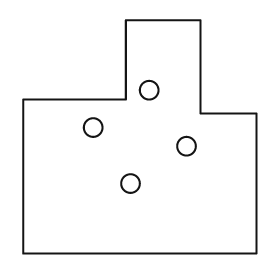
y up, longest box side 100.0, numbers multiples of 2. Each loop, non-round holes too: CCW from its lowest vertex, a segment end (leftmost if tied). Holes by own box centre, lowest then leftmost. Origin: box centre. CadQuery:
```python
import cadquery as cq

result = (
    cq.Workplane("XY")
    .moveTo(-50.0, -50.0)
    .lineTo(50.0, -50.0)
    .lineTo(50.0, 10.0)
    .lineTo(26.0, 10.0)
    .lineTo(26.0, 50.0)
    .lineTo(-6.0, 50.0)
    .lineTo(-6.0, 16.0)
    .lineTo(-50.0, 16.0)
    .close()
    .moveTo(-4.0, -20.0)
    .circle(4.0)
    .moveTo(20.0, -4.0)
    .circle(4.0)
    .moveTo(-20.0, 4.0)
    .circle(4.0)
    .moveTo(4.0, 20.0)
    .circle(4.0)
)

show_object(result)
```